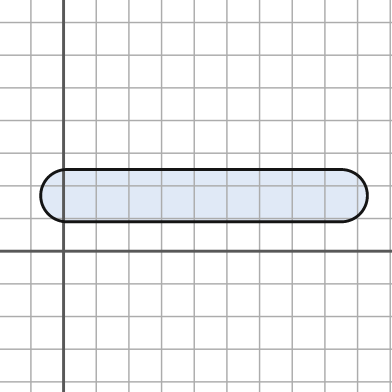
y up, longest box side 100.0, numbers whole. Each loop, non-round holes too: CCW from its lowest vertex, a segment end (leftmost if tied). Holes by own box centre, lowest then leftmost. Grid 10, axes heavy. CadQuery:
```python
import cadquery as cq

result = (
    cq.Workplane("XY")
    .moveTo(1.0, 9.0)
    .lineTo(85.0, 9.0)
    .threePointArc((93.0, 17.0), (85.0, 25.0))
    .lineTo(1.0, 25.0)
    .threePointArc((-7.0, 17.0), (1.0, 9.0))
    .close()
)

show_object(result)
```